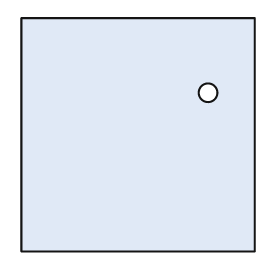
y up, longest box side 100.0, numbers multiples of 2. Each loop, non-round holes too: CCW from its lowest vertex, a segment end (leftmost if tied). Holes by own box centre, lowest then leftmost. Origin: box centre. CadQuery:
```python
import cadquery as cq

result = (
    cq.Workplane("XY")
    .moveTo(-50.0, -50.0)
    .lineTo(50.0, -50.0)
    .lineTo(50.0, 50.0)
    .lineTo(-50.0, 50.0)
    .close()
    .moveTo(30.0, 18.0)
    .circle(4.0)
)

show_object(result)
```